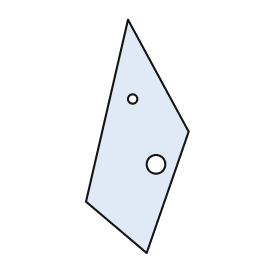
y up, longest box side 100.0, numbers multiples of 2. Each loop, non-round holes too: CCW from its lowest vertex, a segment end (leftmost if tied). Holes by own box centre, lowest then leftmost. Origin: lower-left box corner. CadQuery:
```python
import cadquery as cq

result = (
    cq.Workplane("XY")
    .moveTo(26.0, 0.0)
    .lineTo(44.0, 52.0)
    .lineTo(18.0, 100.0)
    .lineTo(0.0, 22.0)
    .close()
    .moveTo(30.0, 38.0)
    .circle(4.0)
    .moveTo(20.0, 66.0)
    .circle(2.0)
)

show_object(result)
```